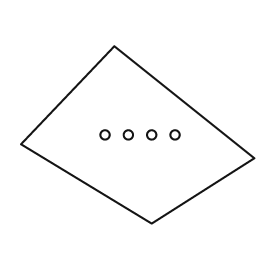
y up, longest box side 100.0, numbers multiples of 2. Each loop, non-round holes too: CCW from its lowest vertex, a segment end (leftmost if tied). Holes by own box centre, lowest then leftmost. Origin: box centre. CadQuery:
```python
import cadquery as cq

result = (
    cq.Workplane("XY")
    .moveTo(6.0, -38.0)
    .lineTo(50.0, -10.0)
    .lineTo(-10.0, 38.0)
    .lineTo(-50.0, -4.0)
    .close()
    .moveTo(-14.0, 0.0)
    .circle(2.0)
    .moveTo(-4.0, 0.0)
    .circle(2.0)
    .moveTo(6.0, 0.0)
    .circle(2.0)
    .moveTo(16.0, 0.0)
    .circle(2.0)
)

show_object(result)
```